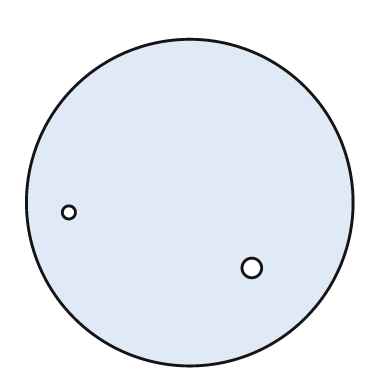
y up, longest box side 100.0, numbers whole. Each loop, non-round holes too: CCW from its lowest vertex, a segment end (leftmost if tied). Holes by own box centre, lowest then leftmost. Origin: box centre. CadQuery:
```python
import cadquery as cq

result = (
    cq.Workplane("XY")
    .moveTo(0.0, 0.0)
    .circle(50.0)
    .moveTo(19.0, -20.0)
    .circle(3.0)
    .moveTo(-37.0, -3.0)
    .circle(2.0)
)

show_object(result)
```